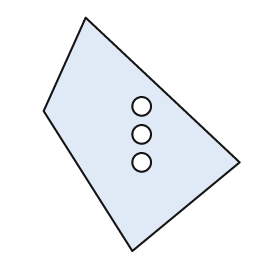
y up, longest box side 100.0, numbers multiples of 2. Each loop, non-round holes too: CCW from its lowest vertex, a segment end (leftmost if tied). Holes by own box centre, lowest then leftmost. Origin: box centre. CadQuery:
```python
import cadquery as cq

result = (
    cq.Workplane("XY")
    .moveTo(-4.0, -50.0)
    .lineTo(42.0, -12.0)
    .lineTo(-24.0, 50.0)
    .lineTo(-42.0, 10.0)
    .close()
    .moveTo(0.0, -12.0)
    .circle(4.0)
    .moveTo(0.0, 0.0)
    .circle(4.0)
    .moveTo(0.0, 12.0)
    .circle(4.0)
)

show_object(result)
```